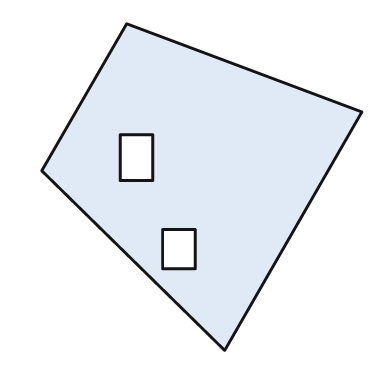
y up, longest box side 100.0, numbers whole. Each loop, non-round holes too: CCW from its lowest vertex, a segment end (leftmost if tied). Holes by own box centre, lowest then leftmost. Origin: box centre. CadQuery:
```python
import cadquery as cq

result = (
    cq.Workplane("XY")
    .moveTo(7.0, -50.0)
    .lineTo(49.0, 23.0)
    .lineTo(-23.0, 50.0)
    .lineTo(-49.0, 5.0)
    .close()
    .moveTo(-12.0, -25.0)
    .lineTo(-2.0, -25.0)
    .lineTo(-2.0, -13.0)
    .lineTo(-12.0, -13.0)
    .close()
    .moveTo(-25.0, 2.0)
    .lineTo(-15.0, 2.0)
    .lineTo(-15.0, 16.0)
    .lineTo(-25.0, 16.0)
    .close()
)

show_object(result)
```